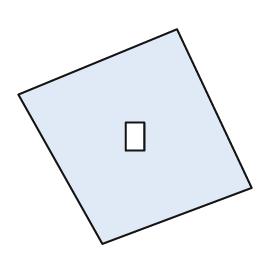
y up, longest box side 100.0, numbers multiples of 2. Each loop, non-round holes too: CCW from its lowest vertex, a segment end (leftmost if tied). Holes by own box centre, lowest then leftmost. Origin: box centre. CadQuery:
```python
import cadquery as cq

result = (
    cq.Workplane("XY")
    .moveTo(-14.0, -46.0)
    .lineTo(50.0, -22.0)
    .lineTo(18.0, 46.0)
    .lineTo(-50.0, 18.0)
    .close()
    .moveTo(-4.0, -6.0)
    .lineTo(4.0, -6.0)
    .lineTo(4.0, 6.0)
    .lineTo(-4.0, 6.0)
    .close()
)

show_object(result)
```